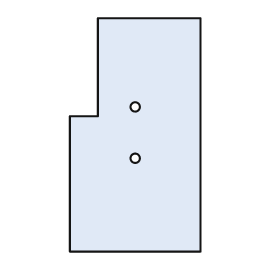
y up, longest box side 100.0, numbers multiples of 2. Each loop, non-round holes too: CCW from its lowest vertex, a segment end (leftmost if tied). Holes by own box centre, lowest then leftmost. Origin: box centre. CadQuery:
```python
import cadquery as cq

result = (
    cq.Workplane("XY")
    .moveTo(-28.0, -50.0)
    .lineTo(28.0, -50.0)
    .lineTo(28.0, 50.0)
    .lineTo(-16.0, 50.0)
    .lineTo(-16.0, 8.0)
    .lineTo(-28.0, 8.0)
    .close()
    .moveTo(0.0, -10.0)
    .circle(2.0)
    .moveTo(0.0, 12.0)
    .circle(2.0)
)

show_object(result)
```